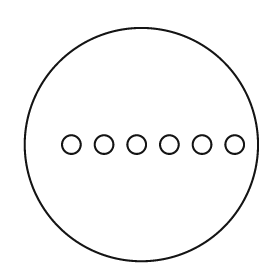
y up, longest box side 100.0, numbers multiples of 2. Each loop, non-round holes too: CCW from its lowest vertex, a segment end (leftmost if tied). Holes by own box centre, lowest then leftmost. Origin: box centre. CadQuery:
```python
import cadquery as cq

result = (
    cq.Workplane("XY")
    .moveTo(0.0, 0.0)
    .circle(50.0)
    .moveTo(-30.0, 0.0)
    .circle(4.0)
    .moveTo(-16.0, 0.0)
    .circle(4.0)
    .moveTo(-2.0, 0.0)
    .circle(4.0)
    .moveTo(12.0, 0.0)
    .circle(4.0)
    .moveTo(26.0, 0.0)
    .circle(4.0)
    .moveTo(40.0, 0.0)
    .circle(4.0)
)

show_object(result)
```